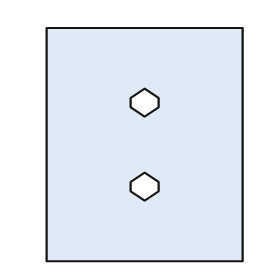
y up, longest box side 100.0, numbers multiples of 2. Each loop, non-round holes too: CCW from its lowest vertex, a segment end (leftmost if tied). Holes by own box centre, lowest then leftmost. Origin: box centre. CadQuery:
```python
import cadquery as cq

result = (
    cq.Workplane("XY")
    .moveTo(-42.0, -50.0)
    .lineTo(42.0, -50.0)
    .lineTo(42.0, 50.0)
    .lineTo(-42.0, 50.0)
    .close()
    .moveTo(0.0, -24.0)
    .lineTo(6.0, -20.0)
    .lineTo(6.0, -16.0)
    .lineTo(0.0, -12.0)
    .lineTo(-6.0, -16.0)
    .lineTo(-6.0, -20.0)
    .close()
    .moveTo(0.0, 12.0)
    .lineTo(6.0, 16.0)
    .lineTo(6.0, 20.0)
    .lineTo(0.0, 24.0)
    .lineTo(-6.0, 20.0)
    .lineTo(-6.0, 16.0)
    .close()
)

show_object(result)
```